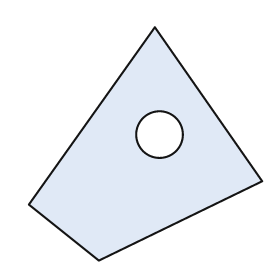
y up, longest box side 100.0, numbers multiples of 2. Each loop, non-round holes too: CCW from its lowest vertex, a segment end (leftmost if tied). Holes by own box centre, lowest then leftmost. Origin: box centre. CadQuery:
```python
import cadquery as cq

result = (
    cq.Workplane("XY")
    .moveTo(-20.0, -50.0)
    .lineTo(50.0, -16.0)
    .lineTo(4.0, 50.0)
    .lineTo(-50.0, -26.0)
    .close()
    .moveTo(6.0, 4.0)
    .circle(10.0)
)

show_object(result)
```